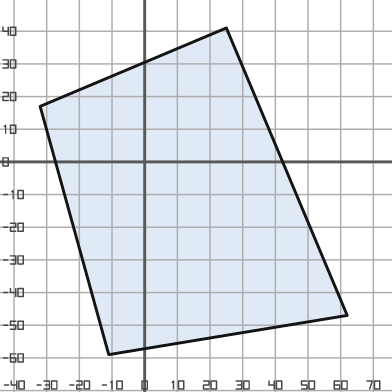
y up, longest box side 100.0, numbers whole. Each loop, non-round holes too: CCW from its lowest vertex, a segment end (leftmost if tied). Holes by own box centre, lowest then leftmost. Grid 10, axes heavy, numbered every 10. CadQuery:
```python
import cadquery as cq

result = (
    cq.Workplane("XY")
    .moveTo(-11.0, -59.0)
    .lineTo(62.0, -47.0)
    .lineTo(25.0, 41.0)
    .lineTo(-32.0, 17.0)
    .close()
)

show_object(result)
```